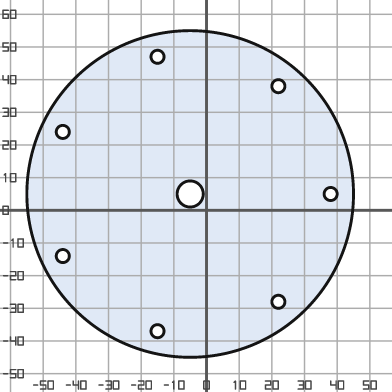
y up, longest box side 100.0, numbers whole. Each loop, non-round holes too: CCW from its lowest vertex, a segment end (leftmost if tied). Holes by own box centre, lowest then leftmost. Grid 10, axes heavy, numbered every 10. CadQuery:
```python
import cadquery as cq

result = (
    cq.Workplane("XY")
    .moveTo(-5.0, 5.0)
    .circle(50.0)
    .moveTo(-15.0, -37.0)
    .circle(2.0)
    .moveTo(22.0, -28.0)
    .circle(2.0)
    .moveTo(-44.0, -14.0)
    .circle(2.0)
    .moveTo(-5.0, 5.0)
    .circle(4.0)
    .moveTo(38.0, 5.0)
    .circle(2.0)
    .moveTo(-44.0, 24.0)
    .circle(2.0)
    .moveTo(22.0, 38.0)
    .circle(2.0)
    .moveTo(-15.0, 47.0)
    .circle(2.0)
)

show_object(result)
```